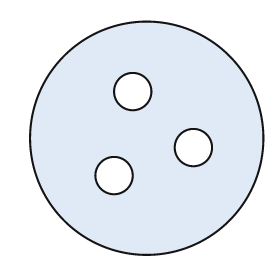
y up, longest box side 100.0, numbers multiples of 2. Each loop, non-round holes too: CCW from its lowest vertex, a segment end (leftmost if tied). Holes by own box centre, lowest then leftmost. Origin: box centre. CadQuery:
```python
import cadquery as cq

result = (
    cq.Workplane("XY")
    .moveTo(0.0, 0.0)
    .circle(50.0)
    .moveTo(-14.0, -16.0)
    .circle(8.0)
    .moveTo(20.0, -4.0)
    .circle(8.0)
    .moveTo(-6.0, 20.0)
    .circle(8.0)
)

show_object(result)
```